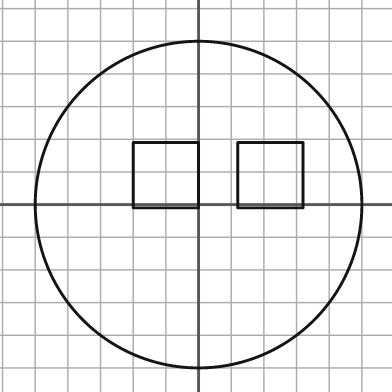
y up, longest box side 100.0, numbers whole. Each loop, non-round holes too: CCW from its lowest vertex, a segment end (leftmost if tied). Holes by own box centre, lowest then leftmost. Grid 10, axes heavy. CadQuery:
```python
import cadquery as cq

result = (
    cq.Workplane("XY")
    .moveTo(0.0, 0.0)
    .circle(50.0)
    .moveTo(-20.0, -1.0)
    .lineTo(0.0, -1.0)
    .lineTo(0.0, 19.0)
    .lineTo(-20.0, 19.0)
    .close()
    .moveTo(12.0, -1.0)
    .lineTo(32.0, -1.0)
    .lineTo(32.0, 19.0)
    .lineTo(12.0, 19.0)
    .close()
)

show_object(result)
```